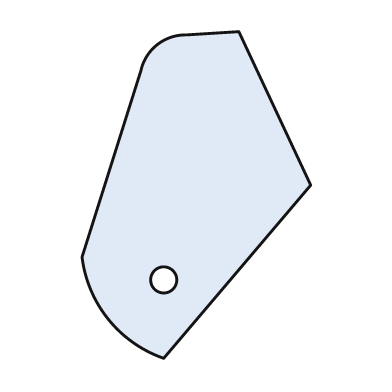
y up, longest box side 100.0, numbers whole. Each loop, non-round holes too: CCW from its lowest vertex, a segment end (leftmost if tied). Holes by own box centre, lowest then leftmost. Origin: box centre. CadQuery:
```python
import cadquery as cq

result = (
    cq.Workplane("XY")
    .moveTo(-10.0, -50.0)
    .lineTo(35.0, 3.0)
    .lineTo(13.0, 50.0)
    .lineTo(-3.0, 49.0)
    .threePointArc((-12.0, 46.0), (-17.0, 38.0))
    .lineTo(-35.0, -19.0)
    .threePointArc((-27.0, -38.0), (-10.0, -50.0))
    .close()
    .moveTo(-10.0, -26.0)
    .circle(4.0)
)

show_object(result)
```